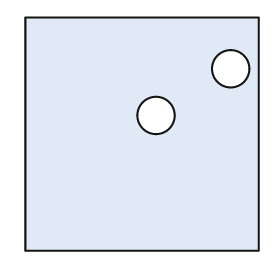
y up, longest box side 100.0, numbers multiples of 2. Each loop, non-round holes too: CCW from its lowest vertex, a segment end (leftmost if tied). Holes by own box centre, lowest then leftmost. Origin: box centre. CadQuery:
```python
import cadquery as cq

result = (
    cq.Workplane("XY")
    .moveTo(-50.0, -50.0)
    .lineTo(50.0, -50.0)
    .lineTo(50.0, 50.0)
    .lineTo(-50.0, 50.0)
    .close()
    .moveTo(6.0, 8.0)
    .circle(8.0)
    .moveTo(38.0, 28.0)
    .circle(8.0)
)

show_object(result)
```